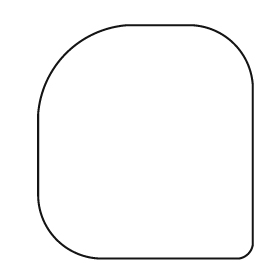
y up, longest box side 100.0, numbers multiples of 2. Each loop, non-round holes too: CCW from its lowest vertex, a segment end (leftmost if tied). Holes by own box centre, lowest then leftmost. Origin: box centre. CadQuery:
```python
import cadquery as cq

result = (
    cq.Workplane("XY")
    .moveTo(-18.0, -50.0)
    .lineTo(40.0, -50.0)
    .threePointArc((44.0, -48.0), (46.0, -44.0))
    .lineTo(46.0, 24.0)
    .threePointArc((38.0, 42.0), (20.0, 50.0))
    .lineTo(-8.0, 50.0)
    .threePointArc((-34.0, 38.0), (-46.0, 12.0))
    .lineTo(-46.0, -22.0)
    .threePointArc((-38.0, -42.0), (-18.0, -50.0))
    .close()
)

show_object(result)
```